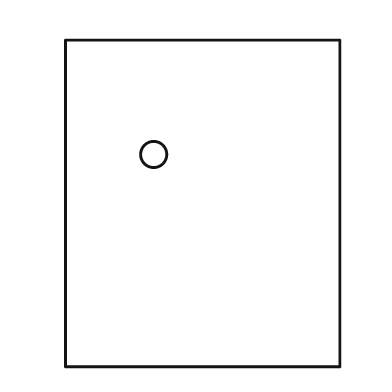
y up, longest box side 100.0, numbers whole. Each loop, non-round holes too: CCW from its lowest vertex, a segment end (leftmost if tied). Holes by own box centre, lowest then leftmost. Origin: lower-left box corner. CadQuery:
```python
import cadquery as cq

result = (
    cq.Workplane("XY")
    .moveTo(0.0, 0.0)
    .lineTo(84.0, 0.0)
    .lineTo(84.0, 100.0)
    .lineTo(0.0, 100.0)
    .close()
    .moveTo(27.0, 65.0)
    .circle(4.0)
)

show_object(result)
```